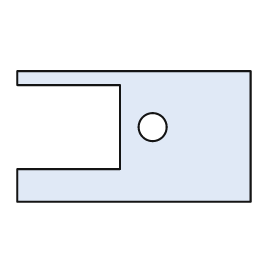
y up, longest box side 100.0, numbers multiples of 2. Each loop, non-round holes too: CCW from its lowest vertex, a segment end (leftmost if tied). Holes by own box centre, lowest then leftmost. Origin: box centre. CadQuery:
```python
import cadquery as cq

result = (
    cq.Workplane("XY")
    .moveTo(-50.0, -28.0)
    .lineTo(50.0, -28.0)
    .lineTo(50.0, 28.0)
    .lineTo(-50.0, 28.0)
    .lineTo(-50.0, 22.0)
    .lineTo(-6.0, 22.0)
    .lineTo(-6.0, -14.0)
    .lineTo(-50.0, -14.0)
    .close()
    .moveTo(8.0, 4.0)
    .circle(6.0)
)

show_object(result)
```